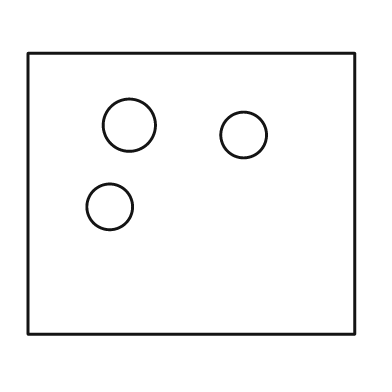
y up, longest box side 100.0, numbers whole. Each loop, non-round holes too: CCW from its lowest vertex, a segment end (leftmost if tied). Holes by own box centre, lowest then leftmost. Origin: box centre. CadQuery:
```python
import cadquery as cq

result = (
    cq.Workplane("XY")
    .moveTo(-50.0, -43.0)
    .lineTo(50.0, -43.0)
    .lineTo(50.0, 43.0)
    .lineTo(-50.0, 43.0)
    .close()
    .moveTo(-25.0, -4.0)
    .circle(7.0)
    .moveTo(16.0, 18.0)
    .circle(7.0)
    .moveTo(-19.0, 21.0)
    .circle(8.0)
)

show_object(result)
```